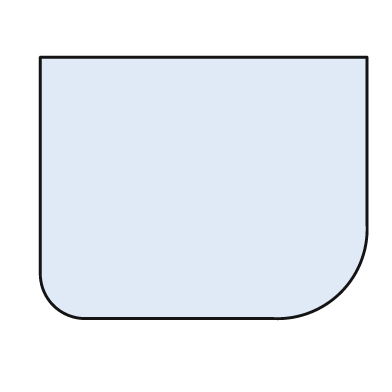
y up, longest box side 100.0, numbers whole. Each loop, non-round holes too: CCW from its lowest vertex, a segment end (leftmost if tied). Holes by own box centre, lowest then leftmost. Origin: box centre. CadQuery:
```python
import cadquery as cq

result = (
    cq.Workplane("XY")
    .moveTo(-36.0, -40.0)
    .lineTo(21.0, -40.0)
    .threePointArc((42.0, -32.0), (50.0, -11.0))
    .lineTo(50.0, 40.0)
    .lineTo(-50.0, 40.0)
    .lineTo(-50.0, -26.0)
    .threePointArc((-46.0, -36.0), (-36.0, -40.0))
    .close()
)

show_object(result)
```